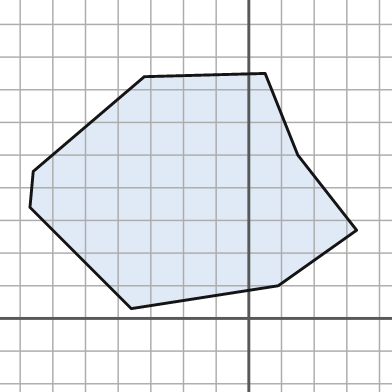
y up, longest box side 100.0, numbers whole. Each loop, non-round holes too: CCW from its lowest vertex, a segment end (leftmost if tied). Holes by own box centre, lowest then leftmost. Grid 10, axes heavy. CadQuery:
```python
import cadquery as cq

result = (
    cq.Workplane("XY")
    .moveTo(-36.0, 3.0)
    .lineTo(9.0, 10.0)
    .lineTo(33.0, 27.0)
    .lineTo(15.0, 50.0)
    .lineTo(5.0, 75.0)
    .lineTo(-32.0, 74.0)
    .lineTo(-66.0, 45.0)
    .lineTo(-67.0, 34.0)
    .close()
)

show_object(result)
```